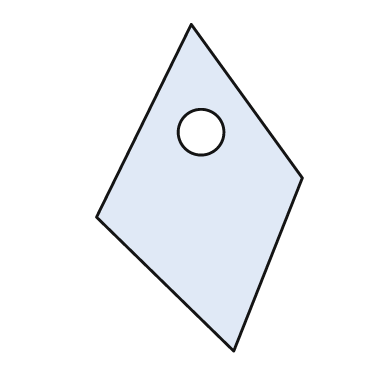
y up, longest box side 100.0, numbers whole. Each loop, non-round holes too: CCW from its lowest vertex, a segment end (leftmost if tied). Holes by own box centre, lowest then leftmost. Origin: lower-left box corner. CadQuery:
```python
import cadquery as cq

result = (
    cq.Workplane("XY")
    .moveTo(42.0, 0.0)
    .lineTo(63.0, 53.0)
    .lineTo(29.0, 100.0)
    .lineTo(0.0, 41.0)
    .close()
    .moveTo(32.0, 67.0)
    .circle(7.0)
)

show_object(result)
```